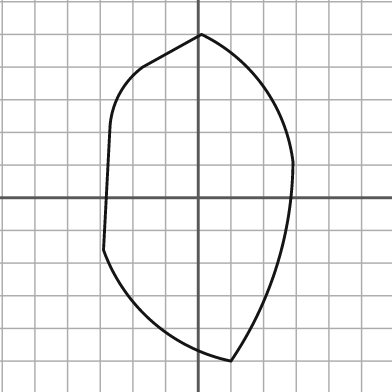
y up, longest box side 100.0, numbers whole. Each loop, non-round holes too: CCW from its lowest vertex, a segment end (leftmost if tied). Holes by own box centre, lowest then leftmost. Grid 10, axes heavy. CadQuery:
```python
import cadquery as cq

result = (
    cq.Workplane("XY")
    .moveTo(10.0, -50.0)
    .threePointArc((24.0, -21.0), (29.0, 11.0))
    .threePointArc((20.0, 34.0), (1.0, 50.0))
    .lineTo(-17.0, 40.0)
    .threePointArc((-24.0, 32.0), (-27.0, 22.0))
    .lineTo(-29.0, -16.0)
    .threePointArc((-14.0, -38.0), (10.0, -50.0))
    .close()
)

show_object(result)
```